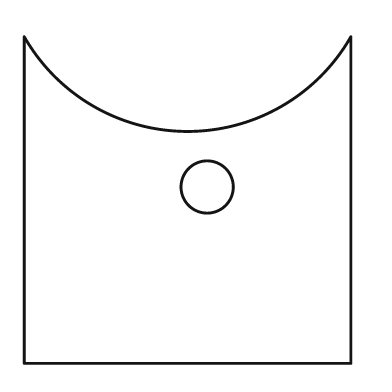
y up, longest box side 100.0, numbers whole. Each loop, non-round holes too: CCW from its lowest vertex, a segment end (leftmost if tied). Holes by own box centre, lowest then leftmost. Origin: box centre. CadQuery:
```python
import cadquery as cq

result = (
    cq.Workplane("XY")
    .moveTo(-50.0, -50.0)
    .lineTo(50.0, -50.0)
    .lineTo(50.0, 50.0)
    .threePointArc((0.0, 21.0), (-50.0, 50.0))
    .close()
    .moveTo(6.0, 4.0)
    .circle(8.0)
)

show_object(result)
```